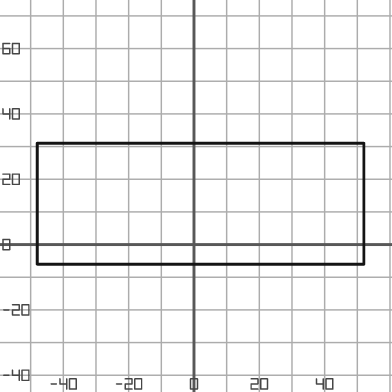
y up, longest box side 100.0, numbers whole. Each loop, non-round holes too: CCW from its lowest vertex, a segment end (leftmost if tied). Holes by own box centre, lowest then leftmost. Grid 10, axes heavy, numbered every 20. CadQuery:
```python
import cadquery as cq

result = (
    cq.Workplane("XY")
    .moveTo(-48.0, -6.0)
    .lineTo(52.0, -6.0)
    .lineTo(52.0, 31.0)
    .lineTo(-48.0, 31.0)
    .close()
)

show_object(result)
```